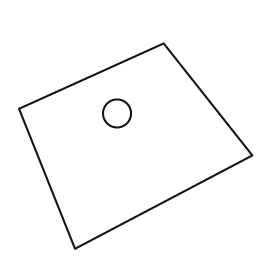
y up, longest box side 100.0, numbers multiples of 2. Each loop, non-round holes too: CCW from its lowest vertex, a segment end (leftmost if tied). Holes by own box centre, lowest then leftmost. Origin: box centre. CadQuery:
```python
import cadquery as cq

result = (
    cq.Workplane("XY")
    .moveTo(-26.0, -44.0)
    .lineTo(50.0, -4.0)
    .lineTo(12.0, 44.0)
    .lineTo(-50.0, 16.0)
    .close()
    .moveTo(-8.0, 14.0)
    .circle(6.0)
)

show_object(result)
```